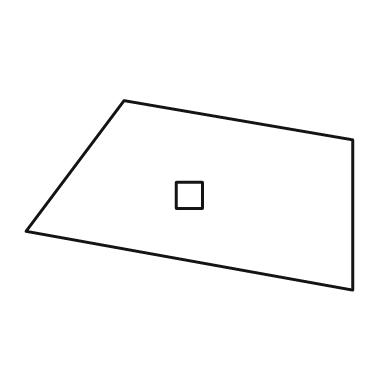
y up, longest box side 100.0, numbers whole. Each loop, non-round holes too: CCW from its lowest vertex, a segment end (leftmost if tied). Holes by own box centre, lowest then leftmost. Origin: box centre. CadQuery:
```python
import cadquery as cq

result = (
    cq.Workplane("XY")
    .moveTo(50.0, -29.0)
    .lineTo(50.0, 17.0)
    .lineTo(-20.0, 29.0)
    .lineTo(-50.0, -11.0)
    .close()
    .moveTo(-4.0, -4.0)
    .lineTo(4.0, -4.0)
    .lineTo(4.0, 4.0)
    .lineTo(-4.0, 4.0)
    .close()
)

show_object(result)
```